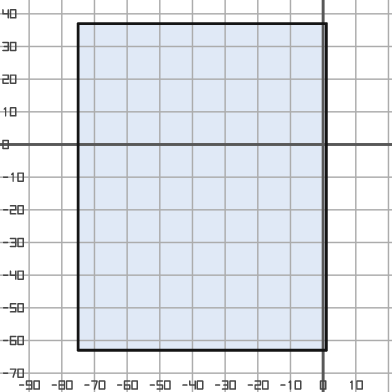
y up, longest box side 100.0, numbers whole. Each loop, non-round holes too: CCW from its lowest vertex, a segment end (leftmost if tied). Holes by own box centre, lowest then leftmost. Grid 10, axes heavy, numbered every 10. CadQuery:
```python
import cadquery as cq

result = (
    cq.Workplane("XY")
    .moveTo(-75.0, -63.0)
    .lineTo(1.0, -63.0)
    .lineTo(1.0, 37.0)
    .lineTo(-75.0, 37.0)
    .close()
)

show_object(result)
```